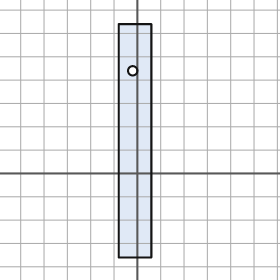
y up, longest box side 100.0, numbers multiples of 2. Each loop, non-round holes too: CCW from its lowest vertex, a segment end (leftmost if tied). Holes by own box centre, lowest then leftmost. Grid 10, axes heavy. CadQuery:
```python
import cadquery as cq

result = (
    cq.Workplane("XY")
    .moveTo(-8.0, -36.0)
    .lineTo(6.0, -36.0)
    .lineTo(6.0, 64.0)
    .lineTo(-8.0, 64.0)
    .close()
    .moveTo(-2.0, 44.0)
    .circle(2.0)
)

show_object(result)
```